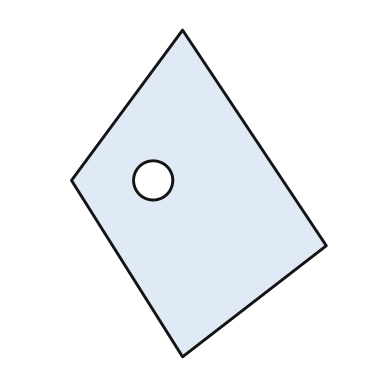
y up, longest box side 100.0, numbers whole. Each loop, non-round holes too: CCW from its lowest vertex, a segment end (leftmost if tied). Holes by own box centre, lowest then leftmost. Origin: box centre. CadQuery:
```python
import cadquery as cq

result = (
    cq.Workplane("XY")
    .moveTo(-5.0, -50.0)
    .lineTo(39.0, -16.0)
    .lineTo(-5.0, 50.0)
    .lineTo(-39.0, 4.0)
    .close()
    .moveTo(-14.0, 4.0)
    .circle(6.0)
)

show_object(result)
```